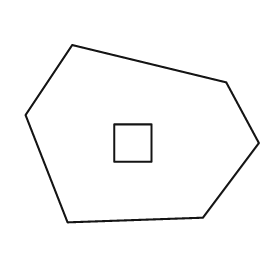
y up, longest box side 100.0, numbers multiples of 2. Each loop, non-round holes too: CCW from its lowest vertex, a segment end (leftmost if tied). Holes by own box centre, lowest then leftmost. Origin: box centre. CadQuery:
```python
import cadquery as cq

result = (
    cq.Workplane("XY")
    .moveTo(-32.0, -38.0)
    .lineTo(26.0, -36.0)
    .lineTo(50.0, -4.0)
    .lineTo(36.0, 22.0)
    .lineTo(-30.0, 38.0)
    .lineTo(-50.0, 8.0)
    .close()
    .moveTo(-12.0, -12.0)
    .lineTo(4.0, -12.0)
    .lineTo(4.0, 4.0)
    .lineTo(-12.0, 4.0)
    .close()
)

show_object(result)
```